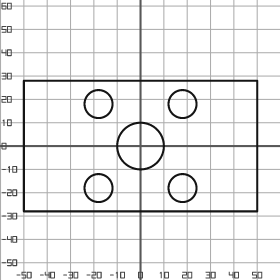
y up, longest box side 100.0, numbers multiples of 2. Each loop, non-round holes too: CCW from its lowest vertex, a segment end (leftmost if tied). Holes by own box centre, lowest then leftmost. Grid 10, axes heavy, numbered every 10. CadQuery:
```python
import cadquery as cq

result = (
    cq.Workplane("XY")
    .moveTo(-50.0, -28.0)
    .lineTo(50.0, -28.0)
    .lineTo(50.0, 28.0)
    .lineTo(-50.0, 28.0)
    .close()
    .moveTo(-18.0, -18.0)
    .circle(6.0)
    .moveTo(18.0, -18.0)
    .circle(6.0)
    .moveTo(0.0, 0.0)
    .circle(10.0)
    .moveTo(-18.0, 18.0)
    .circle(6.0)
    .moveTo(18.0, 18.0)
    .circle(6.0)
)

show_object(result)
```